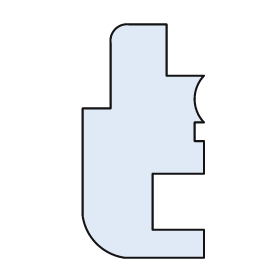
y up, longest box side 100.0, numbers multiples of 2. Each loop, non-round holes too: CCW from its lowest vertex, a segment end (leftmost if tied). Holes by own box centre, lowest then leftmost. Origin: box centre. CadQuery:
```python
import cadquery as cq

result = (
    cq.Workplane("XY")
    .moveTo(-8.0, -50.0)
    .lineTo(26.0, -50.0)
    .lineTo(26.0, -38.0)
    .lineTo(4.0, -38.0)
    .lineTo(4.0, -14.0)
    .lineTo(26.0, -14.0)
    .lineTo(26.0, 0.0)
    .lineTo(22.0, 0.0)
    .lineTo(22.0, 8.0)
    .lineTo(26.0, 8.0)
    .threePointArc((22.0, 18.0), (26.0, 28.0))
    .lineTo(10.0, 28.0)
    .lineTo(10.0, 50.0)
    .lineTo(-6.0, 50.0)
    .threePointArc((-12.0, 48.0), (-14.0, 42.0))
    .lineTo(-14.0, 14.0)
    .lineTo(-26.0, 14.0)
    .lineTo(-26.0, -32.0)
    .threePointArc((-20.0, -44.0), (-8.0, -50.0))
    .close()
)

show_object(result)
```